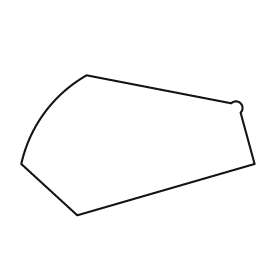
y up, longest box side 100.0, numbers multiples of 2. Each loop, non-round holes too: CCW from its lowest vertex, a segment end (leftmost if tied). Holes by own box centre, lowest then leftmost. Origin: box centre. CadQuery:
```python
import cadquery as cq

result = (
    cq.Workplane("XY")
    .moveTo(-26.0, -30.0)
    .lineTo(50.0, -8.0)
    .lineTo(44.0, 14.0)
    .threePointArc((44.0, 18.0), (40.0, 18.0))
    .lineTo(-22.0, 30.0)
    .threePointArc((-40.0, 14.0), (-50.0, -8.0))
    .close()
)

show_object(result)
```